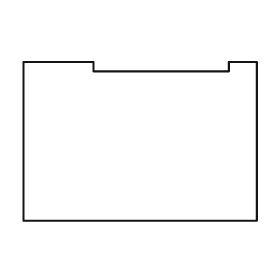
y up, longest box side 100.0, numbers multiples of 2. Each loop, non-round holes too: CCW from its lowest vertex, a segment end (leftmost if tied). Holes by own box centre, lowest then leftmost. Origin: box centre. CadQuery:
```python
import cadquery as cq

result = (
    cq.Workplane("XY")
    .moveTo(-50.0, -34.0)
    .lineTo(50.0, -34.0)
    .lineTo(50.0, 34.0)
    .lineTo(38.0, 34.0)
    .lineTo(38.0, 30.0)
    .lineTo(-20.0, 30.0)
    .lineTo(-20.0, 34.0)
    .lineTo(-50.0, 34.0)
    .close()
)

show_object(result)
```